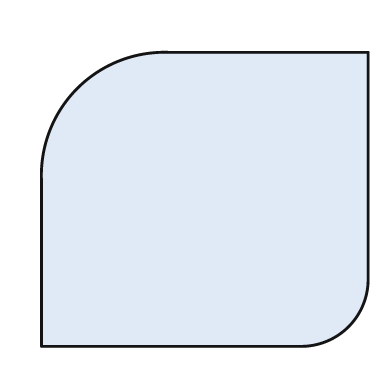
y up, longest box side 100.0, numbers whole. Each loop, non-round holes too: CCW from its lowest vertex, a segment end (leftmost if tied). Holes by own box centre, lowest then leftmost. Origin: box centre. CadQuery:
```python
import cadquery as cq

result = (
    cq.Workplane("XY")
    .moveTo(-50.0, -45.0)
    .lineTo(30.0, -45.0)
    .threePointArc((44.0, -39.0), (50.0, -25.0))
    .lineTo(50.0, 45.0)
    .lineTo(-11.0, 45.0)
    .threePointArc((-39.0, 34.0), (-50.0, 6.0))
    .close()
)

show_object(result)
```